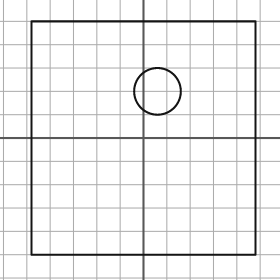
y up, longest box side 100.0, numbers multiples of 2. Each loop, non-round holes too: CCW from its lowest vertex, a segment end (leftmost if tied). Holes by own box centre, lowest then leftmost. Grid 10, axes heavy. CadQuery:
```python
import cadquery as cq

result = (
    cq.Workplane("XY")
    .moveTo(-48.0, -50.0)
    .lineTo(48.0, -50.0)
    .lineTo(48.0, 50.0)
    .lineTo(-48.0, 50.0)
    .close()
    .moveTo(6.0, 20.0)
    .circle(10.0)
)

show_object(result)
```